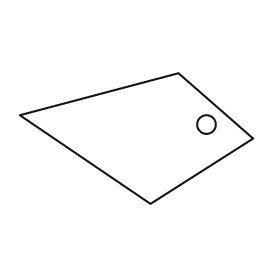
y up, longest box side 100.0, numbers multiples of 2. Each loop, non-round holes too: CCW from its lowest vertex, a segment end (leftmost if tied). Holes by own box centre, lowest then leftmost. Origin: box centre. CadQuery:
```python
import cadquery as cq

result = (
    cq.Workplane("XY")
    .moveTo(6.0, -28.0)
    .lineTo(50.0, 0.0)
    .lineTo(18.0, 28.0)
    .lineTo(-50.0, 10.0)
    .close()
    .moveTo(30.0, 6.0)
    .circle(4.0)
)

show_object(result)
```